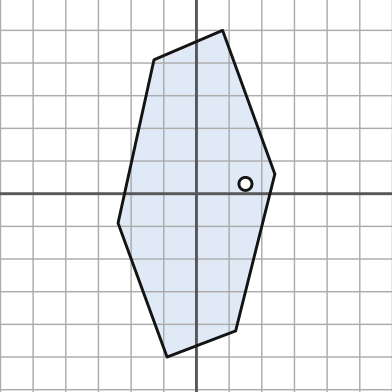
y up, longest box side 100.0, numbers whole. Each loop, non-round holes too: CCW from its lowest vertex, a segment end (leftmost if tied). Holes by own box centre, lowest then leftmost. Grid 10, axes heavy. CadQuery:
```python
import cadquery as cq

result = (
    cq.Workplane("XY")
    .moveTo(-9.0, -50.0)
    .lineTo(12.0, -42.0)
    .lineTo(24.0, 6.0)
    .lineTo(8.0, 50.0)
    .lineTo(-13.0, 41.0)
    .lineTo(-24.0, -9.0)
    .close()
    .moveTo(15.0, 3.0)
    .circle(2.0)
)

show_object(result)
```